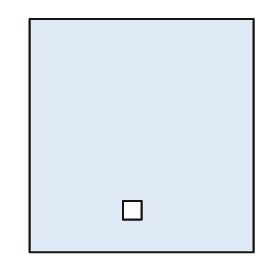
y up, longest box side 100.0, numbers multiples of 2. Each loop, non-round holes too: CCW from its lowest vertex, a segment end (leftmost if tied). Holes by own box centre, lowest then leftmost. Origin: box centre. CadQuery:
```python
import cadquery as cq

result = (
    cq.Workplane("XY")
    .moveTo(-48.0, -50.0)
    .lineTo(48.0, -50.0)
    .lineTo(48.0, 50.0)
    .lineTo(-48.0, 50.0)
    .close()
    .moveTo(-8.0, -36.0)
    .lineTo(0.0, -36.0)
    .lineTo(0.0, -28.0)
    .lineTo(-8.0, -28.0)
    .close()
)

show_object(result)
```